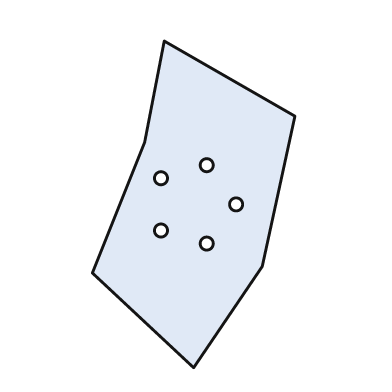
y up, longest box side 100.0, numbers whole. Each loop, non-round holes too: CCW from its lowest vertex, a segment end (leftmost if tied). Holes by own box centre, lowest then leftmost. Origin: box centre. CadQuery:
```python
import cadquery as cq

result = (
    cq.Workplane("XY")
    .moveTo(0.0, -50.0)
    .lineTo(21.0, -19.0)
    .lineTo(31.0, 27.0)
    .lineTo(-9.0, 50.0)
    .lineTo(-15.0, 19.0)
    .lineTo(-31.0, -21.0)
    .close()
    .moveTo(4.0, -12.0)
    .circle(2.0)
    .moveTo(-10.0, -8.0)
    .circle(2.0)
    .moveTo(13.0, 0.0)
    .circle(2.0)
    .moveTo(-10.0, 8.0)
    .circle(2.0)
    .moveTo(4.0, 12.0)
    .circle(2.0)
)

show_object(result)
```